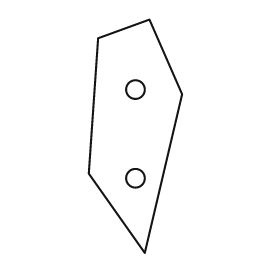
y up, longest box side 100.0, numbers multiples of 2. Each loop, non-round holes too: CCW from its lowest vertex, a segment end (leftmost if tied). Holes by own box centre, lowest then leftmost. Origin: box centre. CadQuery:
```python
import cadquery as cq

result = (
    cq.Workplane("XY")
    .moveTo(4.0, -50.0)
    .lineTo(20.0, 18.0)
    .lineTo(6.0, 50.0)
    .lineTo(-16.0, 42.0)
    .lineTo(-20.0, -16.0)
    .close()
    .moveTo(0.0, -18.0)
    .circle(4.0)
    .moveTo(0.0, 20.0)
    .circle(4.0)
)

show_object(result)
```